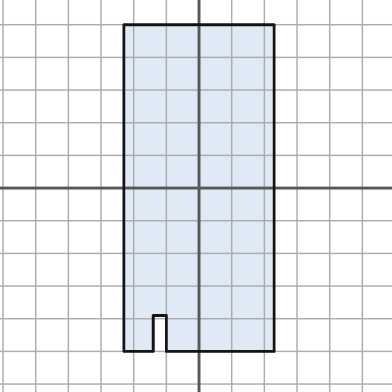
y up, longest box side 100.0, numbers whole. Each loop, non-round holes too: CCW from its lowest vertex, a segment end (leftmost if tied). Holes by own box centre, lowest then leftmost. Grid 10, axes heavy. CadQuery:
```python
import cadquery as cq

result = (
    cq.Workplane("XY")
    .moveTo(-23.0, -50.0)
    .lineTo(-14.0, -50.0)
    .lineTo(-14.0, -39.0)
    .lineTo(-10.0, -39.0)
    .lineTo(-10.0, -50.0)
    .lineTo(23.0, -50.0)
    .lineTo(23.0, 50.0)
    .lineTo(-23.0, 50.0)
    .close()
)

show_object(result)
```